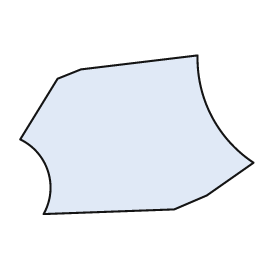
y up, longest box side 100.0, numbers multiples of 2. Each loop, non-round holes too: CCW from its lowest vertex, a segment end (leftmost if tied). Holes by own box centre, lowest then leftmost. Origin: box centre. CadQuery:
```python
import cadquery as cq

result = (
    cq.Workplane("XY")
    .moveTo(-40.0, -34.0)
    .lineTo(16.0, -32.0)
    .lineTo(30.0, -26.0)
    .lineTo(50.0, -12.0)
    .threePointArc((32.0, 8.0), (26.0, 34.0))
    .lineTo(-24.0, 28.0)
    .lineTo(-34.0, 24.0)
    .lineTo(-50.0, -2.0)
    .threePointArc((-38.0, -16.0), (-40.0, -34.0))
    .close()
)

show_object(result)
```